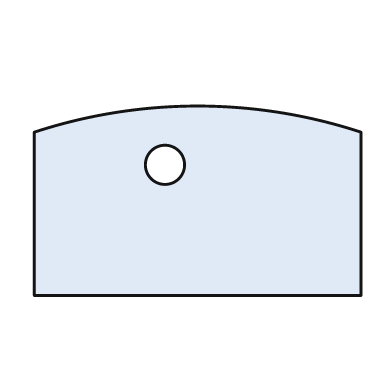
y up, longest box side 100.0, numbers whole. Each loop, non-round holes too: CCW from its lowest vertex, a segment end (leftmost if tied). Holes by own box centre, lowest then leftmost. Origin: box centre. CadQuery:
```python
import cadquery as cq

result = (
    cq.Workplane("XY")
    .moveTo(-50.0, -29.0)
    .lineTo(50.0, -29.0)
    .lineTo(50.0, 21.0)
    .threePointArc((0.0, 29.0), (-50.0, 21.0))
    .close()
    .moveTo(-10.0, 11.0)
    .circle(6.0)
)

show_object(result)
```